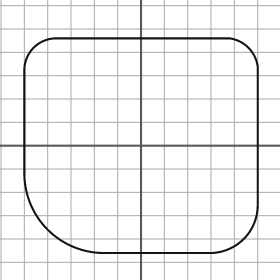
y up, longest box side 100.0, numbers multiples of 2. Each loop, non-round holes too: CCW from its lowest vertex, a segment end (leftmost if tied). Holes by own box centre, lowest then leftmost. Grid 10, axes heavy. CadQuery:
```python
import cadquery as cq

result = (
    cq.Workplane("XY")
    .moveTo(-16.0, -46.0)
    .lineTo(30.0, -46.0)
    .threePointArc((44.0, -40.0), (50.0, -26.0))
    .lineTo(50.0, 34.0)
    .threePointArc((46.0, 42.0), (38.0, 46.0))
    .lineTo(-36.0, 46.0)
    .threePointArc((-46.0, 42.0), (-50.0, 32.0))
    .lineTo(-50.0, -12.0)
    .threePointArc((-40.0, -36.0), (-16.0, -46.0))
    .close()
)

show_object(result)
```